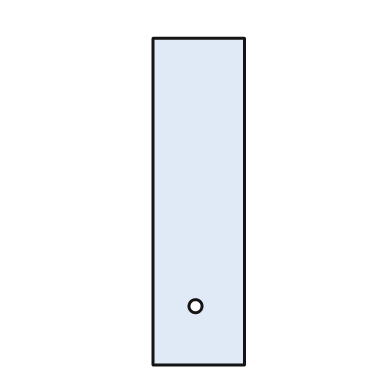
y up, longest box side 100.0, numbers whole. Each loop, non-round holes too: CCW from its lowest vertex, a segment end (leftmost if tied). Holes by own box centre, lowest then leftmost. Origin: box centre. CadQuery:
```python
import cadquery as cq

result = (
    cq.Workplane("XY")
    .moveTo(-14.0, -50.0)
    .lineTo(14.0, -50.0)
    .lineTo(14.0, 50.0)
    .lineTo(-14.0, 50.0)
    .close()
    .moveTo(-1.0, -32.0)
    .circle(2.0)
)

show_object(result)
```